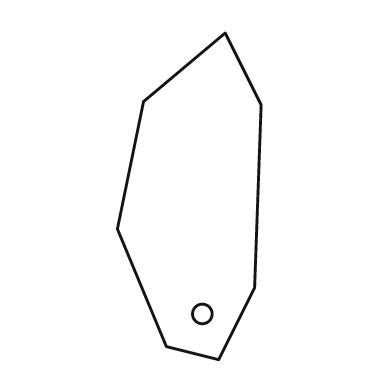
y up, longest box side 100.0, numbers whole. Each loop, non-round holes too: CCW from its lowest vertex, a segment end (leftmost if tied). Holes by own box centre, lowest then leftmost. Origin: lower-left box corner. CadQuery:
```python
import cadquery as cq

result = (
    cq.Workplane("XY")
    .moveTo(31.0, 0.0)
    .lineTo(42.0, 22.0)
    .lineTo(44.0, 78.0)
    .lineTo(33.0, 100.0)
    .lineTo(8.0, 79.0)
    .lineTo(0.0, 40.0)
    .lineTo(15.0, 4.0)
    .close()
    .moveTo(26.0, 14.0)
    .circle(3.0)
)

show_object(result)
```